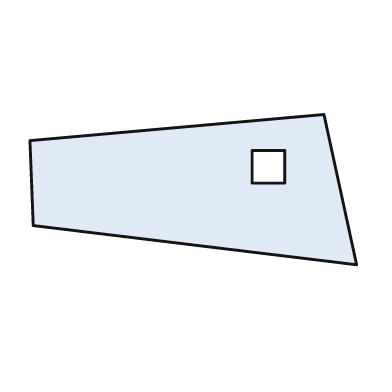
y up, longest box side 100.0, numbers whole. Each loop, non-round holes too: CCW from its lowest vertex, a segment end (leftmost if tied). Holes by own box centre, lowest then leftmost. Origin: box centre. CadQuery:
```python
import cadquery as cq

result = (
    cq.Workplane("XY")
    .moveTo(50.0, -23.0)
    .lineTo(40.0, 23.0)
    .lineTo(-50.0, 15.0)
    .lineTo(-49.0, -11.0)
    .close()
    .moveTo(18.0, 2.0)
    .lineTo(28.0, 2.0)
    .lineTo(28.0, 12.0)
    .lineTo(18.0, 12.0)
    .close()
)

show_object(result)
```